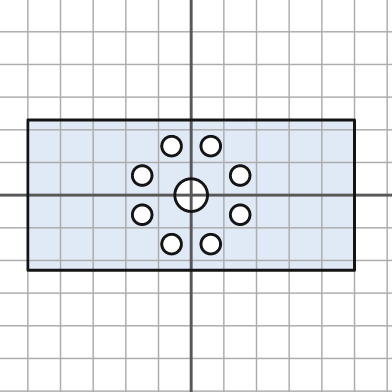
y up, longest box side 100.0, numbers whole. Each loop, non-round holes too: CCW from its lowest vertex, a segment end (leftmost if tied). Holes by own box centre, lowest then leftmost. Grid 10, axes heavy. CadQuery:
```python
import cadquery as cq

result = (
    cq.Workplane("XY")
    .moveTo(-50.0, -23.0)
    .lineTo(50.0, -23.0)
    .lineTo(50.0, 23.0)
    .lineTo(-50.0, 23.0)
    .close()
    .moveTo(-6.0, -15.0)
    .circle(3.0)
    .moveTo(6.0, -15.0)
    .circle(3.0)
    .moveTo(-15.0, -6.0)
    .circle(3.0)
    .moveTo(15.0, -6.0)
    .circle(3.0)
    .moveTo(0.0, 0.0)
    .circle(5.0)
    .moveTo(-15.0, 6.0)
    .circle(3.0)
    .moveTo(15.0, 6.0)
    .circle(3.0)
    .moveTo(-6.0, 15.0)
    .circle(3.0)
    .moveTo(6.0, 15.0)
    .circle(3.0)
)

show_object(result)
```